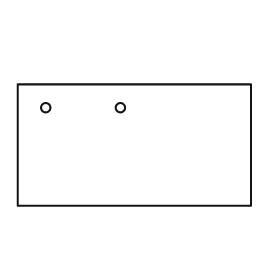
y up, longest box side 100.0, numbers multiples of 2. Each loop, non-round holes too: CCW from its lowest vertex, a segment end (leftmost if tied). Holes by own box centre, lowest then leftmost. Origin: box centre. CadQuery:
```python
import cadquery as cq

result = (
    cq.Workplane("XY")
    .moveTo(-50.0, -26.0)
    .lineTo(50.0, -26.0)
    .lineTo(50.0, 26.0)
    .lineTo(-50.0, 26.0)
    .close()
    .moveTo(-38.0, 16.0)
    .circle(2.0)
    .moveTo(-6.0, 16.0)
    .circle(2.0)
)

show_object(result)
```